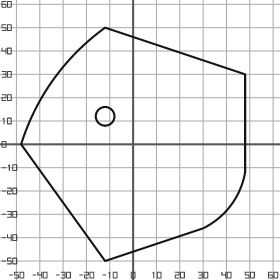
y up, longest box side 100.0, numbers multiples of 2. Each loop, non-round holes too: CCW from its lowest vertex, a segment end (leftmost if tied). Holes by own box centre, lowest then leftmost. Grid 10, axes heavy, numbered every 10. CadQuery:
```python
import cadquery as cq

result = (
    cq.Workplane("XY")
    .moveTo(-12.0, -50.0)
    .lineTo(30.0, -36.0)
    .threePointArc((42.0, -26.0), (48.0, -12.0))
    .lineTo(48.0, 30.0)
    .lineTo(-12.0, 50.0)
    .threePointArc((-34.0, 28.0), (-48.0, 0.0))
    .close()
    .moveTo(-12.0, 12.0)
    .circle(4.0)
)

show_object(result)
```